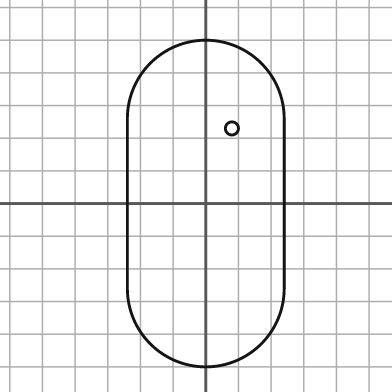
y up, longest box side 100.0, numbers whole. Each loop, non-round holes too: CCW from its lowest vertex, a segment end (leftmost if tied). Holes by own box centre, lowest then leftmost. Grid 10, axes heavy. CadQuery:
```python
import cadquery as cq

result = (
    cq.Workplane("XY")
    .moveTo(-24.0, -26.0)
    .threePointArc((0.0, -50.0), (24.0, -26.0))
    .lineTo(24.0, 26.0)
    .threePointArc((0.0, 50.0), (-24.0, 26.0))
    .close()
    .moveTo(8.0, 23.0)
    .circle(2.0)
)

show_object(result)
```